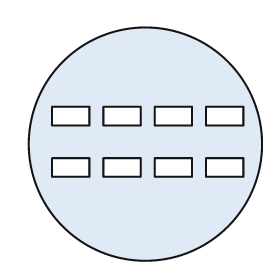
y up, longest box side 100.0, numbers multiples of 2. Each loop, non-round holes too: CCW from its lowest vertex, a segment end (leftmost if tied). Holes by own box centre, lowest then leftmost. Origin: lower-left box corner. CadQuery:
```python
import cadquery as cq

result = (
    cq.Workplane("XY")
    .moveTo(50.0, 50.0)
    .circle(50.0)
    .moveTo(10.0, 36.0)
    .lineTo(26.0, 36.0)
    .lineTo(26.0, 44.0)
    .lineTo(10.0, 44.0)
    .close()
    .moveTo(32.0, 36.0)
    .lineTo(48.0, 36.0)
    .lineTo(48.0, 44.0)
    .lineTo(32.0, 44.0)
    .close()
    .moveTo(54.0, 36.0)
    .lineTo(70.0, 36.0)
    .lineTo(70.0, 44.0)
    .lineTo(54.0, 44.0)
    .close()
    .moveTo(76.0, 36.0)
    .lineTo(92.0, 36.0)
    .lineTo(92.0, 44.0)
    .lineTo(76.0, 44.0)
    .close()
    .moveTo(10.0, 58.0)
    .lineTo(26.0, 58.0)
    .lineTo(26.0, 66.0)
    .lineTo(10.0, 66.0)
    .close()
    .moveTo(32.0, 58.0)
    .lineTo(48.0, 58.0)
    .lineTo(48.0, 66.0)
    .lineTo(32.0, 66.0)
    .close()
    .moveTo(54.0, 58.0)
    .lineTo(70.0, 58.0)
    .lineTo(70.0, 66.0)
    .lineTo(54.0, 66.0)
    .close()
    .moveTo(76.0, 58.0)
    .lineTo(92.0, 58.0)
    .lineTo(92.0, 66.0)
    .lineTo(76.0, 66.0)
    .close()
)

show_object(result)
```